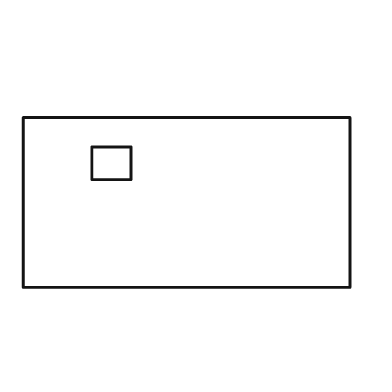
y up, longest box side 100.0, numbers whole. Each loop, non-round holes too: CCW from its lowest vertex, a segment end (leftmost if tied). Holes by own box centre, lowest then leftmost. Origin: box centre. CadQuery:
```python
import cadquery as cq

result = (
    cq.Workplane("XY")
    .moveTo(-50.0, -26.0)
    .lineTo(50.0, -26.0)
    .lineTo(50.0, 26.0)
    .lineTo(-50.0, 26.0)
    .close()
    .moveTo(-29.0, 7.0)
    .lineTo(-17.0, 7.0)
    .lineTo(-17.0, 17.0)
    .lineTo(-29.0, 17.0)
    .close()
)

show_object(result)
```